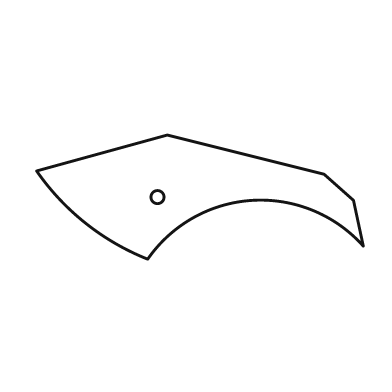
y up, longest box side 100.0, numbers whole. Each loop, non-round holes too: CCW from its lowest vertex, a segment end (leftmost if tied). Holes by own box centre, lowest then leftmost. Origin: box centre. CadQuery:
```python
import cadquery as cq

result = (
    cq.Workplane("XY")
    .moveTo(-16.0, -19.0)
    .threePointArc((16.0, -1.0), (50.0, -15.0))
    .lineTo(47.0, -1.0)
    .lineTo(38.0, 7.0)
    .lineTo(-10.0, 19.0)
    .lineTo(-50.0, 8.0)
    .threePointArc((-35.0, -8.0), (-16.0, -19.0))
    .close()
    .moveTo(-13.0, 0.0)
    .circle(2.0)
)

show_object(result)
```